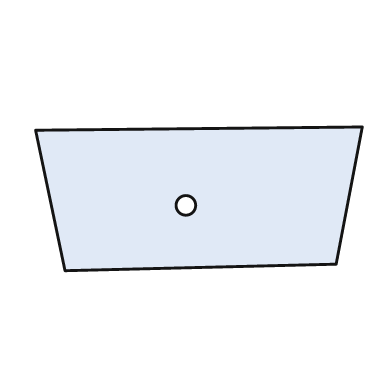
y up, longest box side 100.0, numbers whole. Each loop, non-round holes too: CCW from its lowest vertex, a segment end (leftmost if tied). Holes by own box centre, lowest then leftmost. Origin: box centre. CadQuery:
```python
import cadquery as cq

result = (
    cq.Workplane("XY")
    .moveTo(-41.0, -22.0)
    .lineTo(42.0, -20.0)
    .lineTo(50.0, 22.0)
    .lineTo(-50.0, 21.0)
    .close()
    .moveTo(-4.0, -2.0)
    .circle(3.0)
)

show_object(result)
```